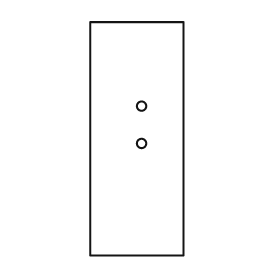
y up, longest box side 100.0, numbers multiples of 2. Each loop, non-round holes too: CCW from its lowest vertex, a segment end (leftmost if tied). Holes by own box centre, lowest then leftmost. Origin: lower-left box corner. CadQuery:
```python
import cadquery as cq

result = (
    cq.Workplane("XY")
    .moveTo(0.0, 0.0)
    .lineTo(40.0, 0.0)
    .lineTo(40.0, 100.0)
    .lineTo(0.0, 100.0)
    .close()
    .moveTo(22.0, 48.0)
    .circle(2.0)
    .moveTo(22.0, 64.0)
    .circle(2.0)
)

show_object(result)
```